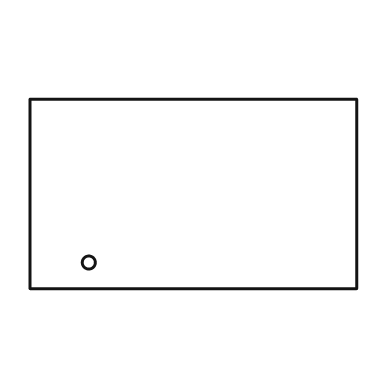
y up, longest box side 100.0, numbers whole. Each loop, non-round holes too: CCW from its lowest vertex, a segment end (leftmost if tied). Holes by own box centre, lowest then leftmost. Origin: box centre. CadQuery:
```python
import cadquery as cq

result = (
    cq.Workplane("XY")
    .moveTo(-50.0, -29.0)
    .lineTo(50.0, -29.0)
    .lineTo(50.0, 29.0)
    .lineTo(-50.0, 29.0)
    .close()
    .moveTo(-32.0, -21.0)
    .circle(2.0)
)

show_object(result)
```